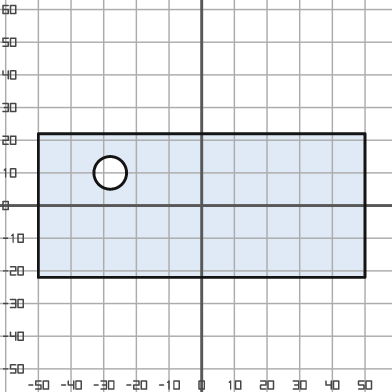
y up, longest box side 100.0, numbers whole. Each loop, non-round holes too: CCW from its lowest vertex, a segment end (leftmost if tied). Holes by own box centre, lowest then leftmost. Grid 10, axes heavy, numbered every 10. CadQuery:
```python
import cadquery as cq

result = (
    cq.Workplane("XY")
    .moveTo(-50.0, -22.0)
    .lineTo(50.0, -22.0)
    .lineTo(50.0, 22.0)
    .lineTo(-50.0, 22.0)
    .close()
    .moveTo(-28.0, 10.0)
    .circle(5.0)
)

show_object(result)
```